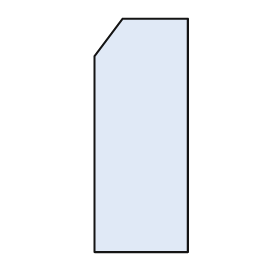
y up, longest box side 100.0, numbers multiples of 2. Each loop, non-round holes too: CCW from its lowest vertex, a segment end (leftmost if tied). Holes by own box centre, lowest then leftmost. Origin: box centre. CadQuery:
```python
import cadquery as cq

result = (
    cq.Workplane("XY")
    .moveTo(-20.0, -50.0)
    .lineTo(20.0, -50.0)
    .lineTo(20.0, 50.0)
    .lineTo(-8.0, 50.0)
    .lineTo(-20.0, 34.0)
    .close()
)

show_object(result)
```